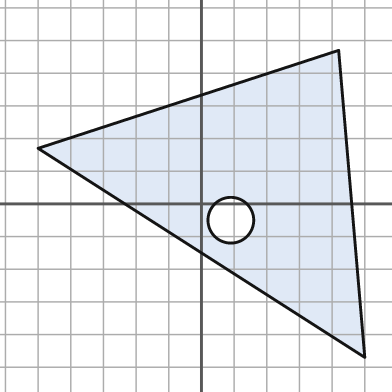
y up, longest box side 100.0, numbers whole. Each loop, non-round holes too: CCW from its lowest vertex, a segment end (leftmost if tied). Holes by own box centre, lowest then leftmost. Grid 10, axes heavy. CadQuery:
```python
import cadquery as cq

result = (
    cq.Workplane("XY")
    .moveTo(50.0, -47.0)
    .lineTo(42.0, 47.0)
    .lineTo(-50.0, 17.0)
    .close()
    .moveTo(9.0, -5.0)
    .circle(7.0)
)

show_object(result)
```